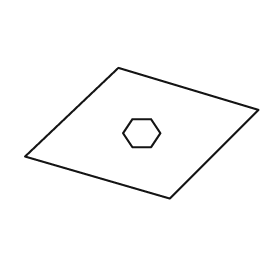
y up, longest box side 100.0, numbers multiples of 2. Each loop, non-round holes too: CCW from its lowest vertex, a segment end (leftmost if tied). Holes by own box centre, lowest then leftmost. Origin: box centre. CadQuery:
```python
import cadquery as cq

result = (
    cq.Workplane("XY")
    .moveTo(12.0, -28.0)
    .lineTo(50.0, 10.0)
    .lineTo(-10.0, 28.0)
    .lineTo(-50.0, -10.0)
    .close()
    .moveTo(-4.0, -6.0)
    .lineTo(4.0, -6.0)
    .lineTo(8.0, 0.0)
    .lineTo(4.0, 6.0)
    .lineTo(-4.0, 6.0)
    .lineTo(-8.0, 0.0)
    .close()
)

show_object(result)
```